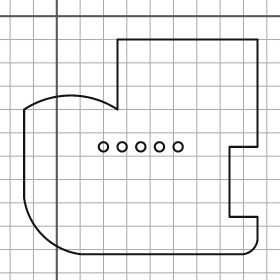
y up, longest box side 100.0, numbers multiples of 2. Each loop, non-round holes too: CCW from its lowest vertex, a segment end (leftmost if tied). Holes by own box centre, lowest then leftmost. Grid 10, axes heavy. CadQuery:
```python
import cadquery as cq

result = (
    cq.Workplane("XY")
    .moveTo(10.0, -102.0)
    .lineTo(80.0, -102.0)
    .threePointArc((84.0, -100.0), (86.0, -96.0))
    .lineTo(86.0, -86.0)
    .lineTo(74.0, -86.0)
    .lineTo(74.0, -56.0)
    .lineTo(86.0, -56.0)
    .lineTo(86.0, -10.0)
    .lineTo(26.0, -10.0)
    .lineTo(26.0, -40.0)
    .threePointArc((6.0, -34.0), (-14.0, -40.0))
    .lineTo(-14.0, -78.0)
    .threePointArc((-6.0, -94.0), (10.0, -102.0))
    .close()
    .moveTo(20.0, -56.0)
    .circle(2.0)
    .moveTo(28.0, -56.0)
    .circle(2.0)
    .moveTo(36.0, -56.0)
    .circle(2.0)
    .moveTo(44.0, -56.0)
    .circle(2.0)
    .moveTo(52.0, -56.0)
    .circle(2.0)
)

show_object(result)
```